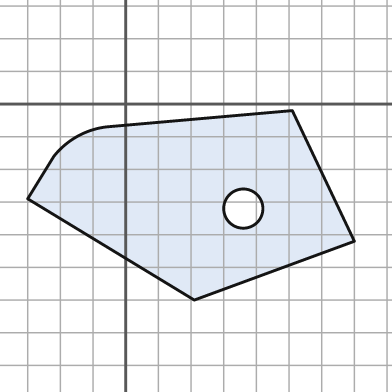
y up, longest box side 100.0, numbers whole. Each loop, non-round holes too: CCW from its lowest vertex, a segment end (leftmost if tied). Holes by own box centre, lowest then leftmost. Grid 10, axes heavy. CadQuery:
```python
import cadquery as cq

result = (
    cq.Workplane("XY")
    .moveTo(21.0, -60.0)
    .lineTo(70.0, -42.0)
    .lineTo(51.0, -2.0)
    .lineTo(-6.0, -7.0)
    .threePointArc((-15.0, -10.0), (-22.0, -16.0))
    .lineTo(-30.0, -29.0)
    .close()
    .moveTo(36.0, -32.0)
    .circle(6.0)
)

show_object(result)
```